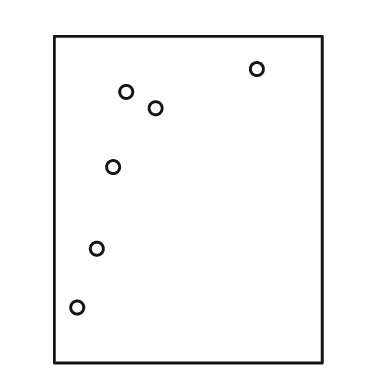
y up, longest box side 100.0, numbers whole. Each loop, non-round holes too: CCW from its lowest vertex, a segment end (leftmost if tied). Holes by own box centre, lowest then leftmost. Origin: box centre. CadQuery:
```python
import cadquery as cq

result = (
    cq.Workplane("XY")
    .moveTo(-41.0, -50.0)
    .lineTo(41.0, -50.0)
    .lineTo(41.0, 50.0)
    .lineTo(-41.0, 50.0)
    .close()
    .moveTo(-34.0, -33.0)
    .circle(2.0)
    .moveTo(-28.0, -15.0)
    .circle(2.0)
    .moveTo(-23.0, 10.0)
    .circle(2.0)
    .moveTo(-10.0, 28.0)
    .circle(2.0)
    .moveTo(-19.0, 33.0)
    .circle(2.0)
    .moveTo(21.0, 40.0)
    .circle(2.0)
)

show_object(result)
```